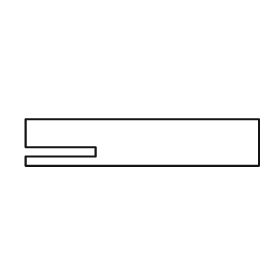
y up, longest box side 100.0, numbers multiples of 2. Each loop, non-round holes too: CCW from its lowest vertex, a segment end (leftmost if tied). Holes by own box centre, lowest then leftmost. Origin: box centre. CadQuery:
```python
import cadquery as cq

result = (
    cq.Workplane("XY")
    .moveTo(-50.0, -10.0)
    .lineTo(50.0, -10.0)
    .lineTo(50.0, 10.0)
    .lineTo(-50.0, 10.0)
    .lineTo(-50.0, -2.0)
    .lineTo(-20.0, -2.0)
    .lineTo(-20.0, -6.0)
    .lineTo(-50.0, -6.0)
    .close()
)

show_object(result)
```